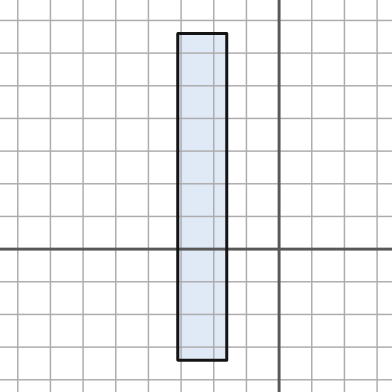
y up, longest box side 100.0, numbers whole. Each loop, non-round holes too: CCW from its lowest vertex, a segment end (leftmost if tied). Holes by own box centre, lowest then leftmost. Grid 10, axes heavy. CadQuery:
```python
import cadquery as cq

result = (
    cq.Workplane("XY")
    .moveTo(-31.0, -34.0)
    .lineTo(-16.0, -34.0)
    .lineTo(-16.0, 66.0)
    .lineTo(-31.0, 66.0)
    .close()
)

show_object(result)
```